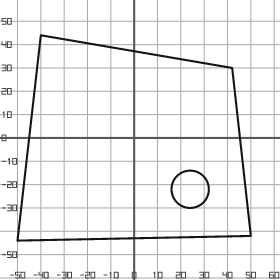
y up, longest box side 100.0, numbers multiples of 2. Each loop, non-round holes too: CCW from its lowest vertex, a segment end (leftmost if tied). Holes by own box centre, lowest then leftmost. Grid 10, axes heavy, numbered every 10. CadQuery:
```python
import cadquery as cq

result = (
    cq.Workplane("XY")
    .moveTo(-50.0, -44.0)
    .lineTo(50.0, -42.0)
    .lineTo(42.0, 30.0)
    .lineTo(-40.0, 44.0)
    .close()
    .moveTo(24.0, -22.0)
    .circle(8.0)
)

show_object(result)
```